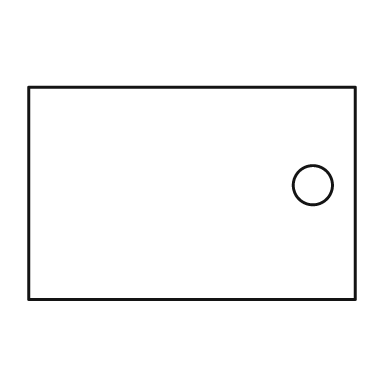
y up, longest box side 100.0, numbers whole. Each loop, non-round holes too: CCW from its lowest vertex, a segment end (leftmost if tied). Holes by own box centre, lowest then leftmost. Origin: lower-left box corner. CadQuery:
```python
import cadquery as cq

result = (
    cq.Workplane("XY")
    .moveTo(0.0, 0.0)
    .lineTo(100.0, 0.0)
    .lineTo(100.0, 65.0)
    .lineTo(0.0, 65.0)
    .close()
    .moveTo(87.0, 35.0)
    .circle(6.0)
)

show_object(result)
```